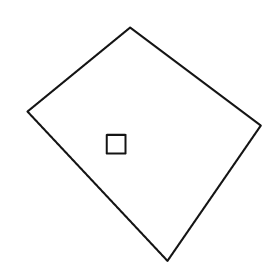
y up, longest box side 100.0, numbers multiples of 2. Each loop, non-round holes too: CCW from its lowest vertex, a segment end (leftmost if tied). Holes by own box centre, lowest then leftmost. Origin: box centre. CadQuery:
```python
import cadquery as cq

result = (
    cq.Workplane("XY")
    .moveTo(10.0, -50.0)
    .lineTo(50.0, 8.0)
    .lineTo(-6.0, 50.0)
    .lineTo(-50.0, 14.0)
    .close()
    .moveTo(-16.0, -4.0)
    .lineTo(-8.0, -4.0)
    .lineTo(-8.0, 4.0)
    .lineTo(-16.0, 4.0)
    .close()
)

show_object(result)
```